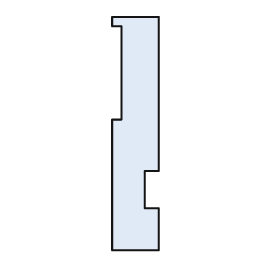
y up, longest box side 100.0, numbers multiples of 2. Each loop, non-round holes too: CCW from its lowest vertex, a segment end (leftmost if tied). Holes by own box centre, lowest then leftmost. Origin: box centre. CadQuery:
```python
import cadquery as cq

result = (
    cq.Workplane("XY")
    .moveTo(-10.0, -50.0)
    .lineTo(10.0, -50.0)
    .lineTo(10.0, -32.0)
    .lineTo(4.0, -32.0)
    .lineTo(4.0, -16.0)
    .lineTo(10.0, -16.0)
    .lineTo(10.0, 50.0)
    .lineTo(-10.0, 50.0)
    .lineTo(-10.0, 46.0)
    .lineTo(-6.0, 46.0)
    .lineTo(-6.0, 6.0)
    .lineTo(-10.0, 6.0)
    .close()
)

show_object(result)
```